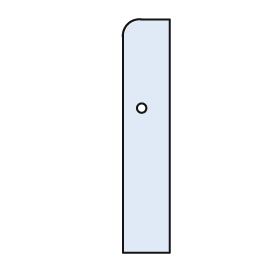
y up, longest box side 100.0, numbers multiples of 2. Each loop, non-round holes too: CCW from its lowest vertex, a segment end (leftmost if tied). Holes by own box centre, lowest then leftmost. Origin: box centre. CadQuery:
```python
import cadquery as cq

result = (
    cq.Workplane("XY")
    .moveTo(-10.0, -50.0)
    .lineTo(10.0, -50.0)
    .lineTo(10.0, 50.0)
    .lineTo(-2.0, 50.0)
    .threePointArc((-8.0, 48.0), (-10.0, 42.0))
    .close()
    .moveTo(-2.0, 12.0)
    .circle(2.0)
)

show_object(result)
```